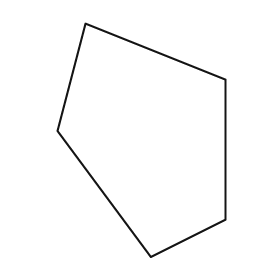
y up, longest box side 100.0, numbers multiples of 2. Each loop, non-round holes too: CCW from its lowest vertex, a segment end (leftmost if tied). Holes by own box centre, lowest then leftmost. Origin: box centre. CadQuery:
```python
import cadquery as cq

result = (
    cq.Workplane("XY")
    .moveTo(4.0, -50.0)
    .lineTo(36.0, -34.0)
    .lineTo(36.0, 26.0)
    .lineTo(-24.0, 50.0)
    .lineTo(-36.0, 4.0)
    .close()
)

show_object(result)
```